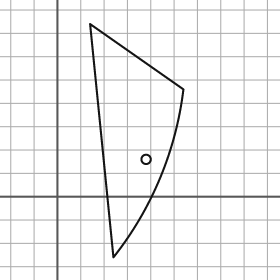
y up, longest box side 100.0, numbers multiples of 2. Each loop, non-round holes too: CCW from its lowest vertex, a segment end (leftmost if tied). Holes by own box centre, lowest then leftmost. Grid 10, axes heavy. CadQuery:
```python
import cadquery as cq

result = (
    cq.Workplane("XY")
    .moveTo(24.0, -26.0)
    .threePointArc((44.0, 8.0), (54.0, 46.0))
    .lineTo(14.0, 74.0)
    .close()
    .moveTo(38.0, 16.0)
    .circle(2.0)
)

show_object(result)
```